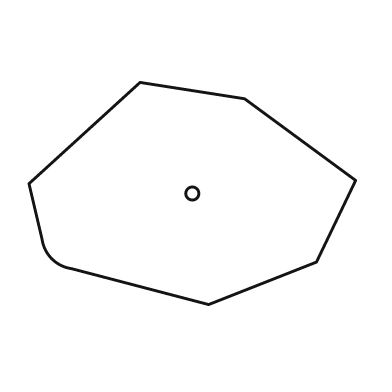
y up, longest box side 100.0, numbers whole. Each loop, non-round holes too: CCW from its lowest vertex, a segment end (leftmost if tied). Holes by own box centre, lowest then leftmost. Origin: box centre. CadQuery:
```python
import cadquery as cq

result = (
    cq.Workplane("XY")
    .moveTo(5.0, -34.0)
    .lineTo(38.0, -21.0)
    .lineTo(50.0, 4.0)
    .lineTo(16.0, 29.0)
    .lineTo(-16.0, 34.0)
    .lineTo(-50.0, 3.0)
    .lineTo(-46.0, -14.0)
    .threePointArc((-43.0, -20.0), (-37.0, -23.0))
    .close()
    .moveTo(0.0, 0.0)
    .circle(2.0)
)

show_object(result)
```